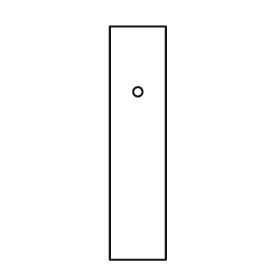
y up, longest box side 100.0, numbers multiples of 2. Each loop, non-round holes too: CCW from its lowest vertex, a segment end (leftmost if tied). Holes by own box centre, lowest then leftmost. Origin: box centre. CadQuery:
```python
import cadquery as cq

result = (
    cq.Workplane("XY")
    .moveTo(-12.0, -50.0)
    .lineTo(12.0, -50.0)
    .lineTo(12.0, 50.0)
    .lineTo(-12.0, 50.0)
    .close()
    .moveTo(0.0, 22.0)
    .circle(2.0)
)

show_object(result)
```